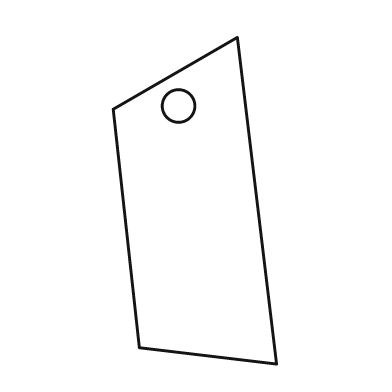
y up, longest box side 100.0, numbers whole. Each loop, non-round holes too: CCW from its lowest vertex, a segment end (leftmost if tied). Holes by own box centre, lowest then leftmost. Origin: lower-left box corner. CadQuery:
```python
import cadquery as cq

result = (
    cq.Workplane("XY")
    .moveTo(50.0, 0.0)
    .lineTo(38.0, 100.0)
    .lineTo(0.0, 78.0)
    .lineTo(8.0, 5.0)
    .close()
    .moveTo(20.0, 79.0)
    .circle(5.0)
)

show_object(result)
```